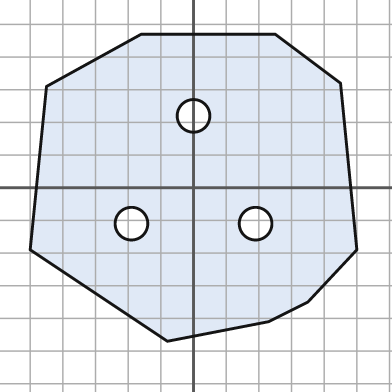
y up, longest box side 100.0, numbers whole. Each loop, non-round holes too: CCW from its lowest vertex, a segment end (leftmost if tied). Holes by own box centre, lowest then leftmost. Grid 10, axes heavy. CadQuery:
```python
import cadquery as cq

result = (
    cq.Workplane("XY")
    .moveTo(-8.0, -47.0)
    .lineTo(23.0, -41.0)
    .lineTo(35.0, -35.0)
    .lineTo(50.0, -19.0)
    .lineTo(45.0, 32.0)
    .lineTo(25.0, 47.0)
    .lineTo(-16.0, 47.0)
    .lineTo(-45.0, 31.0)
    .lineTo(-50.0, -19.0)
    .close()
    .moveTo(-19.0, -11.0)
    .circle(5.0)
    .moveTo(19.0, -11.0)
    .circle(5.0)
    .moveTo(0.0, 22.0)
    .circle(5.0)
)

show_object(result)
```